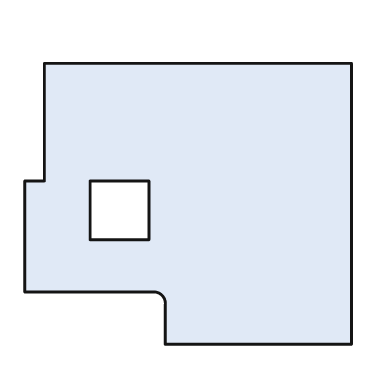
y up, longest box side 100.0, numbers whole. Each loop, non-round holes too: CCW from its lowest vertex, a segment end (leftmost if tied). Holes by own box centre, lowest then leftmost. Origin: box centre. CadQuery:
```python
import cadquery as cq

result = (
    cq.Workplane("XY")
    .moveTo(-7.0, -43.0)
    .lineTo(50.0, -43.0)
    .lineTo(50.0, 43.0)
    .lineTo(-44.0, 43.0)
    .lineTo(-44.0, 7.0)
    .lineTo(-50.0, 7.0)
    .lineTo(-50.0, -27.0)
    .lineTo(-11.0, -27.0)
    .threePointArc((-8.0, -28.0), (-7.0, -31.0))
    .close()
    .moveTo(-30.0, -11.0)
    .lineTo(-12.0, -11.0)
    .lineTo(-12.0, 7.0)
    .lineTo(-30.0, 7.0)
    .close()
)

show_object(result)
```